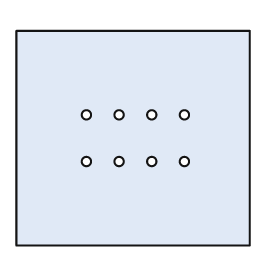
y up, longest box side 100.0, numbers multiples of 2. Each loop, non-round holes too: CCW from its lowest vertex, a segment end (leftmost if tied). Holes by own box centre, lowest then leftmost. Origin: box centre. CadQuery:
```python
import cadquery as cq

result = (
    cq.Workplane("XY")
    .moveTo(-50.0, -46.0)
    .lineTo(50.0, -46.0)
    .lineTo(50.0, 46.0)
    .lineTo(-50.0, 46.0)
    .close()
    .moveTo(-20.0, -10.0)
    .circle(2.0)
    .moveTo(-6.0, -10.0)
    .circle(2.0)
    .moveTo(8.0, -10.0)
    .circle(2.0)
    .moveTo(22.0, -10.0)
    .circle(2.0)
    .moveTo(-20.0, 10.0)
    .circle(2.0)
    .moveTo(-6.0, 10.0)
    .circle(2.0)
    .moveTo(8.0, 10.0)
    .circle(2.0)
    .moveTo(22.0, 10.0)
    .circle(2.0)
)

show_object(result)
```